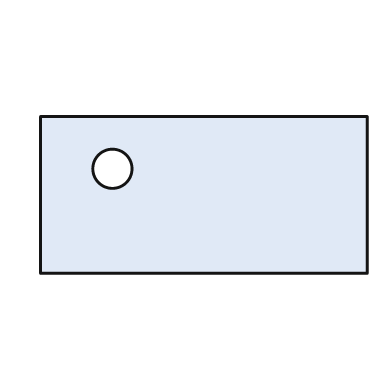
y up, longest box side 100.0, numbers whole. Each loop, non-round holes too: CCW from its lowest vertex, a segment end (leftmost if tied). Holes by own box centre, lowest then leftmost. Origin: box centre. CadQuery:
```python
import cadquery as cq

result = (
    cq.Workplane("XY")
    .moveTo(-50.0, -24.0)
    .lineTo(50.0, -24.0)
    .lineTo(50.0, 24.0)
    .lineTo(-50.0, 24.0)
    .close()
    .moveTo(-28.0, 8.0)
    .circle(6.0)
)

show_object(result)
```